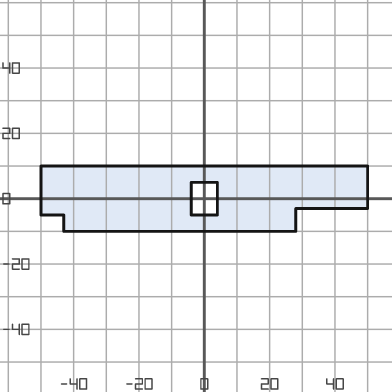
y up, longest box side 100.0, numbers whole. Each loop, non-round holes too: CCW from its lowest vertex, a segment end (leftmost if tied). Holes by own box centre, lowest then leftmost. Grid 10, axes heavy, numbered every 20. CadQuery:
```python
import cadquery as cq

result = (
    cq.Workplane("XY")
    .moveTo(-43.0, -10.0)
    .lineTo(28.0, -10.0)
    .lineTo(28.0, -3.0)
    .lineTo(50.0, -3.0)
    .lineTo(50.0, 10.0)
    .lineTo(-50.0, 10.0)
    .lineTo(-50.0, -5.0)
    .lineTo(-43.0, -5.0)
    .close()
    .moveTo(-4.0, -5.0)
    .lineTo(4.0, -5.0)
    .lineTo(4.0, 5.0)
    .lineTo(-4.0, 5.0)
    .close()
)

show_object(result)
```